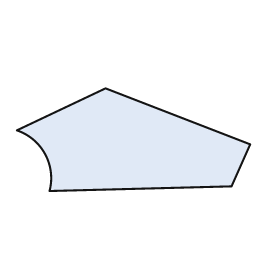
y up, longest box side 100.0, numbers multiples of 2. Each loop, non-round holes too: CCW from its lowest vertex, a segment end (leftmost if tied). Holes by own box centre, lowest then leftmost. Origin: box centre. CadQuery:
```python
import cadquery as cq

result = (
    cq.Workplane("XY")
    .moveTo(-36.0, -22.0)
    .lineTo(42.0, -20.0)
    .lineTo(50.0, -2.0)
    .lineTo(-12.0, 22.0)
    .lineTo(-50.0, 4.0)
    .threePointArc((-38.0, -6.0), (-36.0, -22.0))
    .close()
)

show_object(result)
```